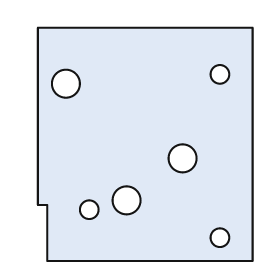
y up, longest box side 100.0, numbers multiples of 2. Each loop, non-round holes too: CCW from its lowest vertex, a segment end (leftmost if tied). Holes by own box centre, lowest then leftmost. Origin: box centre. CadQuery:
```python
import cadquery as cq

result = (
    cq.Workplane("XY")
    .moveTo(-42.0, -50.0)
    .lineTo(46.0, -50.0)
    .lineTo(46.0, 50.0)
    .lineTo(-46.0, 50.0)
    .lineTo(-46.0, -26.0)
    .lineTo(-42.0, -26.0)
    .close()
    .moveTo(32.0, -40.0)
    .circle(4.0)
    .moveTo(-24.0, -28.0)
    .circle(4.0)
    .moveTo(-8.0, -24.0)
    .circle(6.0)
    .moveTo(16.0, -6.0)
    .circle(6.0)
    .moveTo(-34.0, 26.0)
    .circle(6.0)
    .moveTo(32.0, 30.0)
    .circle(4.0)
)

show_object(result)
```